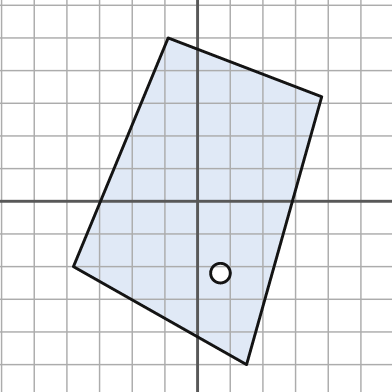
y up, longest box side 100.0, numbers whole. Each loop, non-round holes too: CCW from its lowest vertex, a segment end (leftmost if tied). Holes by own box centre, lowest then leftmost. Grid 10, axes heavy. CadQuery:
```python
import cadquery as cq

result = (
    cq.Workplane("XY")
    .moveTo(15.0, -50.0)
    .lineTo(38.0, 32.0)
    .lineTo(-9.0, 50.0)
    .lineTo(-38.0, -20.0)
    .close()
    .moveTo(7.0, -22.0)
    .circle(3.0)
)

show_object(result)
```